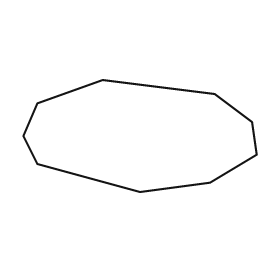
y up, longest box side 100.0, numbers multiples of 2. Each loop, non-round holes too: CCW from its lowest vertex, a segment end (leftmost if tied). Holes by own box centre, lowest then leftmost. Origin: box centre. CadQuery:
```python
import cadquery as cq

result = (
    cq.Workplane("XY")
    .moveTo(0.0, -24.0)
    .lineTo(30.0, -20.0)
    .lineTo(50.0, -8.0)
    .lineTo(48.0, 6.0)
    .lineTo(32.0, 18.0)
    .lineTo(-16.0, 24.0)
    .lineTo(-44.0, 14.0)
    .lineTo(-50.0, 0.0)
    .lineTo(-44.0, -12.0)
    .close()
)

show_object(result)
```